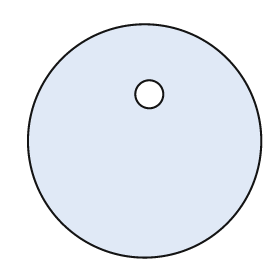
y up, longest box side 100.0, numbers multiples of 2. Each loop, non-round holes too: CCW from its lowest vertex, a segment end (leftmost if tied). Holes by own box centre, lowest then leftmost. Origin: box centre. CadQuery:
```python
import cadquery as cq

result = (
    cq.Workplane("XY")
    .moveTo(0.0, 0.0)
    .circle(50.0)
    .moveTo(2.0, 20.0)
    .circle(6.0)
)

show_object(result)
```